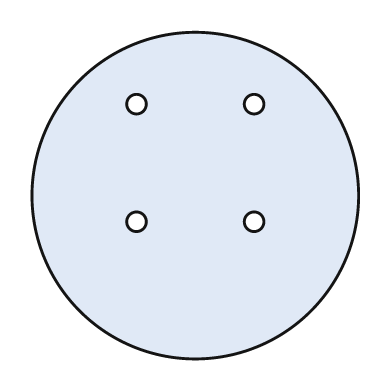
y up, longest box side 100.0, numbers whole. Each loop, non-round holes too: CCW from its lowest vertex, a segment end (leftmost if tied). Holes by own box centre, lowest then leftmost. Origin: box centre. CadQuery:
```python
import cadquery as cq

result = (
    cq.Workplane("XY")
    .moveTo(0.0, 0.0)
    .circle(50.0)
    .moveTo(-18.0, -8.0)
    .circle(3.0)
    .moveTo(18.0, -8.0)
    .circle(3.0)
    .moveTo(-18.0, 28.0)
    .circle(3.0)
    .moveTo(18.0, 28.0)
    .circle(3.0)
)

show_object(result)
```